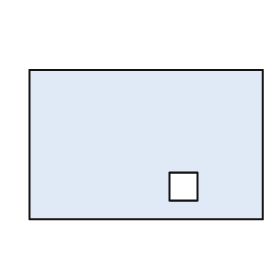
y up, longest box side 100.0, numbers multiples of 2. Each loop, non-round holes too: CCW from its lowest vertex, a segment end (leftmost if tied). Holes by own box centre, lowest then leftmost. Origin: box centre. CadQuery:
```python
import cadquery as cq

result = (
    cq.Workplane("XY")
    .moveTo(-50.0, -32.0)
    .lineTo(50.0, -32.0)
    .lineTo(50.0, 32.0)
    .lineTo(-50.0, 32.0)
    .close()
    .moveTo(10.0, -24.0)
    .lineTo(22.0, -24.0)
    .lineTo(22.0, -12.0)
    .lineTo(10.0, -12.0)
    .close()
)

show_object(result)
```